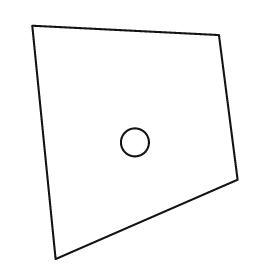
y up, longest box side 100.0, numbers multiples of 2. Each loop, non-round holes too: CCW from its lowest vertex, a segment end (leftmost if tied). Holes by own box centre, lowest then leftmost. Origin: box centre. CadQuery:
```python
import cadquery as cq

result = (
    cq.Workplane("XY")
    .moveTo(-34.0, -50.0)
    .lineTo(44.0, -16.0)
    .lineTo(36.0, 46.0)
    .lineTo(-44.0, 50.0)
    .close()
    .moveTo(0.0, 0.0)
    .circle(6.0)
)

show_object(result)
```